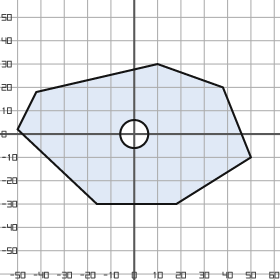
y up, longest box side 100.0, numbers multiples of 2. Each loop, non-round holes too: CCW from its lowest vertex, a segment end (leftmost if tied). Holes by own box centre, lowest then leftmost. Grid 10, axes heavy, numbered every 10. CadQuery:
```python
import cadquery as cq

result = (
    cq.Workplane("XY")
    .moveTo(-16.0, -30.0)
    .lineTo(18.0, -30.0)
    .lineTo(50.0, -10.0)
    .lineTo(38.0, 20.0)
    .lineTo(10.0, 30.0)
    .lineTo(-42.0, 18.0)
    .lineTo(-50.0, 2.0)
    .close()
    .moveTo(0.0, 0.0)
    .circle(6.0)
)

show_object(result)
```